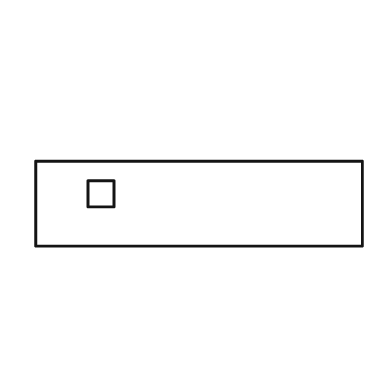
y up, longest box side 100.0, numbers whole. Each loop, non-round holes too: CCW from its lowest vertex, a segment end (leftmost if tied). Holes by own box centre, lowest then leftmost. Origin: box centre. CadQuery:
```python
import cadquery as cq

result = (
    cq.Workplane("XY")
    .moveTo(-50.0, -13.0)
    .lineTo(50.0, -13.0)
    .lineTo(50.0, 13.0)
    .lineTo(-50.0, 13.0)
    .close()
    .moveTo(-34.0, -1.0)
    .lineTo(-26.0, -1.0)
    .lineTo(-26.0, 7.0)
    .lineTo(-34.0, 7.0)
    .close()
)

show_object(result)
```